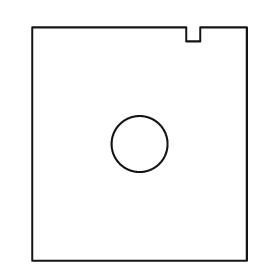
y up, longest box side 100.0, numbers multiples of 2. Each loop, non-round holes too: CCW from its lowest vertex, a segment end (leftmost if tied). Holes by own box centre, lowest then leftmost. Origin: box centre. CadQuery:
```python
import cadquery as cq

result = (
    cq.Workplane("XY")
    .moveTo(-46.0, -50.0)
    .lineTo(46.0, -50.0)
    .lineTo(46.0, 50.0)
    .lineTo(26.0, 50.0)
    .lineTo(26.0, 44.0)
    .lineTo(20.0, 44.0)
    .lineTo(20.0, 50.0)
    .lineTo(-46.0, 50.0)
    .close()
    .moveTo(0.0, 0.0)
    .circle(12.0)
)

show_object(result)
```